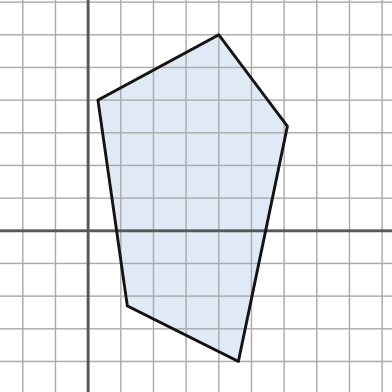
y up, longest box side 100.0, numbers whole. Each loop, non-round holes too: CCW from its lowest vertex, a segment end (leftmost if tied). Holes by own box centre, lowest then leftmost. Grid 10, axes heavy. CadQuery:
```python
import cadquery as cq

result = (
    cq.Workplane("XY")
    .moveTo(46.0, -40.0)
    .lineTo(61.0, 32.0)
    .lineTo(40.0, 60.0)
    .lineTo(3.0, 40.0)
    .lineTo(12.0, -23.0)
    .close()
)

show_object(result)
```